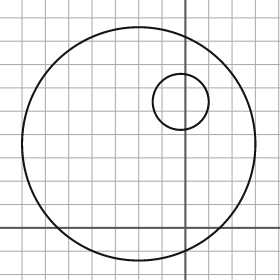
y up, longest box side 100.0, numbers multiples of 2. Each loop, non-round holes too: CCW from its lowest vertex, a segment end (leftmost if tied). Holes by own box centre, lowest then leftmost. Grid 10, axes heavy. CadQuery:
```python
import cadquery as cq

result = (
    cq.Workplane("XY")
    .moveTo(-20.0, 36.0)
    .circle(50.0)
    .moveTo(-2.0, 54.0)
    .circle(12.0)
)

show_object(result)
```